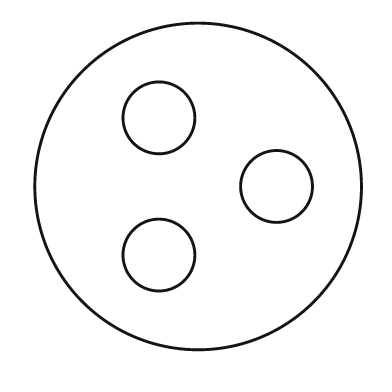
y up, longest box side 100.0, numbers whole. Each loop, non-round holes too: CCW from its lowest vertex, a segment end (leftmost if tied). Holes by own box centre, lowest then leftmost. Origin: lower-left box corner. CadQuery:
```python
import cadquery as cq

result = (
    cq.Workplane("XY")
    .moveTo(50.0, 50.0)
    .circle(50.0)
    .moveTo(38.0, 29.0)
    .circle(11.0)
    .moveTo(74.0, 50.0)
    .circle(11.0)
    .moveTo(38.0, 71.0)
    .circle(11.0)
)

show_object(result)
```